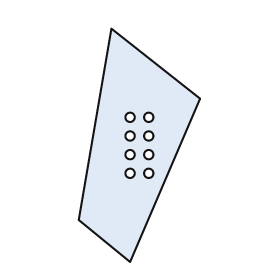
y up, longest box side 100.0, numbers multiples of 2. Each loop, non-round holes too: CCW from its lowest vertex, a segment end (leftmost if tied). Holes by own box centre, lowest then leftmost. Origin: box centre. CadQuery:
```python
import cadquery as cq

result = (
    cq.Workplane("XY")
    .moveTo(-4.0, -50.0)
    .lineTo(26.0, 20.0)
    .lineTo(-12.0, 50.0)
    .lineTo(-26.0, -32.0)
    .close()
    .moveTo(-4.0, -12.0)
    .circle(2.0)
    .moveTo(4.0, -12.0)
    .circle(2.0)
    .moveTo(-4.0, -4.0)
    .circle(2.0)
    .moveTo(4.0, -4.0)
    .circle(2.0)
    .moveTo(-4.0, 4.0)
    .circle(2.0)
    .moveTo(4.0, 4.0)
    .circle(2.0)
    .moveTo(-4.0, 12.0)
    .circle(2.0)
    .moveTo(4.0, 12.0)
    .circle(2.0)
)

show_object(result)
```